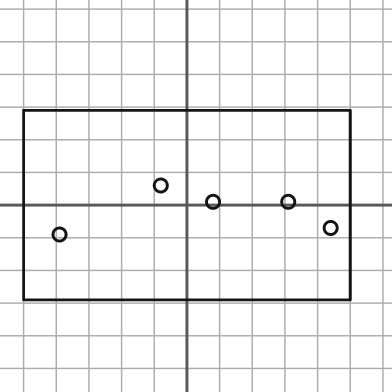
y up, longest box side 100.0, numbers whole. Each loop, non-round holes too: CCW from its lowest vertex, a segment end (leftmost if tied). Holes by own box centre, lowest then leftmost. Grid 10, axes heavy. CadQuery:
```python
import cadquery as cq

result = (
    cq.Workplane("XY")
    .moveTo(-50.0, -29.0)
    .lineTo(50.0, -29.0)
    .lineTo(50.0, 29.0)
    .lineTo(-50.0, 29.0)
    .close()
    .moveTo(-39.0, -9.0)
    .circle(2.0)
    .moveTo(44.0, -7.0)
    .circle(2.0)
    .moveTo(8.0, 1.0)
    .circle(2.0)
    .moveTo(31.0, 1.0)
    .circle(2.0)
    .moveTo(-8.0, 6.0)
    .circle(2.0)
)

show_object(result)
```